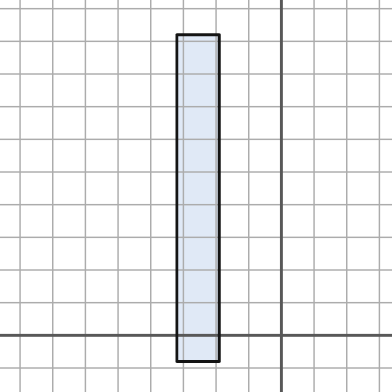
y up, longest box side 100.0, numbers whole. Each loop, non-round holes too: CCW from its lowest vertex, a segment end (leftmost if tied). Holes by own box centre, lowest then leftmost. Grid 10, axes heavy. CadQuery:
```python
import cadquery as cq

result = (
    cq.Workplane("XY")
    .moveTo(-32.0, -8.0)
    .lineTo(-19.0, -8.0)
    .lineTo(-19.0, 92.0)
    .lineTo(-32.0, 92.0)
    .close()
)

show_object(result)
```